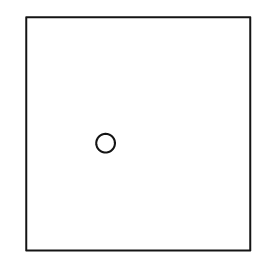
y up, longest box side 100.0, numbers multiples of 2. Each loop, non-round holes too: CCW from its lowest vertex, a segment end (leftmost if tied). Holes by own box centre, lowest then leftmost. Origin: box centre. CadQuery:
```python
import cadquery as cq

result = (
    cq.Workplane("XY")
    .moveTo(-48.0, -50.0)
    .lineTo(48.0, -50.0)
    .lineTo(48.0, 50.0)
    .lineTo(-48.0, 50.0)
    .close()
    .moveTo(-14.0, -4.0)
    .circle(4.0)
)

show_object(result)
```